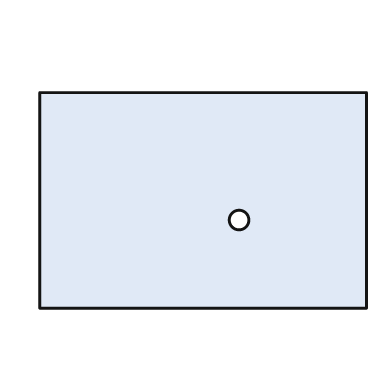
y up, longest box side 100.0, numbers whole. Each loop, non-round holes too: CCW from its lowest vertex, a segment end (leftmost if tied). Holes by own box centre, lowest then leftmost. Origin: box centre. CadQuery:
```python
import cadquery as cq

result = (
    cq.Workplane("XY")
    .moveTo(-50.0, -33.0)
    .lineTo(50.0, -33.0)
    .lineTo(50.0, 33.0)
    .lineTo(-50.0, 33.0)
    .close()
    .moveTo(11.0, -6.0)
    .circle(3.0)
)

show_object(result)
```